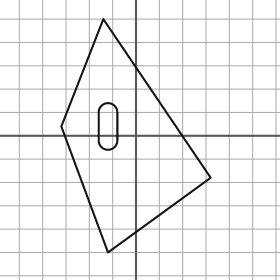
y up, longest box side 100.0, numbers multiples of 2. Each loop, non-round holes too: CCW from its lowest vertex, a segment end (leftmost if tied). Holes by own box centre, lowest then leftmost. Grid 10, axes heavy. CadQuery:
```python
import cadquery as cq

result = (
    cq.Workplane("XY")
    .moveTo(-12.0, -50.0)
    .lineTo(32.0, -18.0)
    .lineTo(-14.0, 50.0)
    .lineTo(-32.0, 4.0)
    .close()
    .moveTo(-16.0, -2.0)
    .threePointArc((-12.0, -6.0), (-8.0, -2.0))
    .lineTo(-8.0, 10.0)
    .threePointArc((-12.0, 14.0), (-16.0, 10.0))
    .close()
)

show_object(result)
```